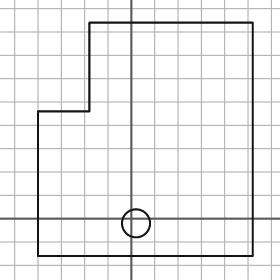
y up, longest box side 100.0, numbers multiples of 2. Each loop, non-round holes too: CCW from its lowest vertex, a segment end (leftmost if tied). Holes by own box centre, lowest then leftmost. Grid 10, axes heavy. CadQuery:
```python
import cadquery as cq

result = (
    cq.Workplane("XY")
    .moveTo(-40.0, -16.0)
    .lineTo(52.0, -16.0)
    .lineTo(52.0, 84.0)
    .lineTo(-18.0, 84.0)
    .lineTo(-18.0, 46.0)
    .lineTo(-40.0, 46.0)
    .close()
    .moveTo(2.0, -2.0)
    .circle(6.0)
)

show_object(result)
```